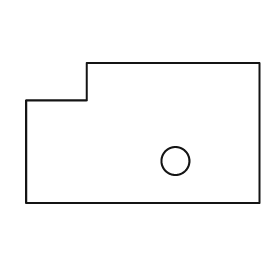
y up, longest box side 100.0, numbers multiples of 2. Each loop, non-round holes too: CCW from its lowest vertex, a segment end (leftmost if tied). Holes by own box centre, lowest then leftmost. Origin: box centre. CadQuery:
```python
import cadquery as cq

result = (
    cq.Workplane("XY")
    .moveTo(-50.0, -30.0)
    .lineTo(50.0, -30.0)
    .lineTo(50.0, 30.0)
    .lineTo(-24.0, 30.0)
    .lineTo(-24.0, 14.0)
    .lineTo(-50.0, 14.0)
    .close()
    .moveTo(14.0, -12.0)
    .circle(6.0)
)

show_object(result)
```